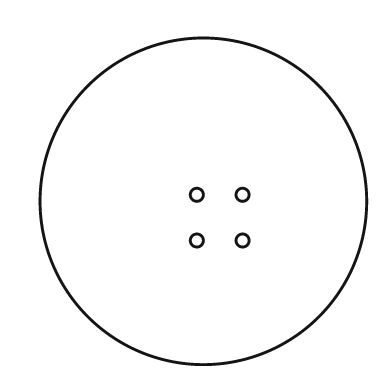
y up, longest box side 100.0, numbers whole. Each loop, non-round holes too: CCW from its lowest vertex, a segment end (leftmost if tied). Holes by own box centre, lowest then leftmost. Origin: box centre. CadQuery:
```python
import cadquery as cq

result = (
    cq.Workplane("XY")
    .moveTo(0.0, 0.0)
    .circle(50.0)
    .moveTo(-2.0, -12.0)
    .circle(2.0)
    .moveTo(12.0, -12.0)
    .circle(2.0)
    .moveTo(-2.0, 2.0)
    .circle(2.0)
    .moveTo(12.0, 2.0)
    .circle(2.0)
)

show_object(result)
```